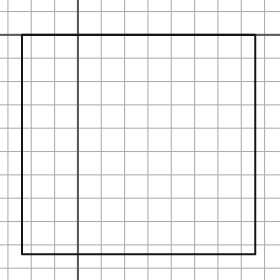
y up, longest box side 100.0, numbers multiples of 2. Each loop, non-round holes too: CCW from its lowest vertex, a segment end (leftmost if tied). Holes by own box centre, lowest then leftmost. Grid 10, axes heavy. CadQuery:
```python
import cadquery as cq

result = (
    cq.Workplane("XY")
    .moveTo(-24.0, -94.0)
    .lineTo(76.0, -94.0)
    .lineTo(76.0, 0.0)
    .lineTo(-24.0, 0.0)
    .close()
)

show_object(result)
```